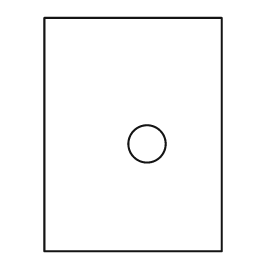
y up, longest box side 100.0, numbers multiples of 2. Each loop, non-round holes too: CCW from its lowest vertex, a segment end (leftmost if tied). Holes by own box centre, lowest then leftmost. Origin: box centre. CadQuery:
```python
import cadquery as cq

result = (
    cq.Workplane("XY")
    .moveTo(-38.0, -50.0)
    .lineTo(38.0, -50.0)
    .lineTo(38.0, 50.0)
    .lineTo(-38.0, 50.0)
    .close()
    .moveTo(6.0, -4.0)
    .circle(8.0)
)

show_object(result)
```